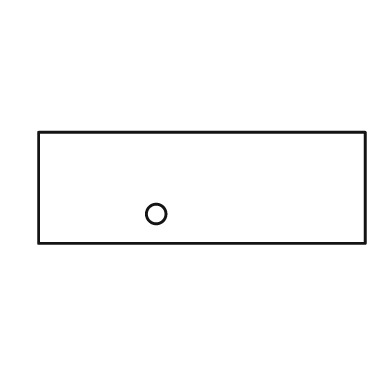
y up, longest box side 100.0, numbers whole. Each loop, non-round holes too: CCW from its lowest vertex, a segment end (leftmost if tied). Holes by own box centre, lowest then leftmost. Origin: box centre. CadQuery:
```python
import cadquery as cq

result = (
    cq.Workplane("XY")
    .moveTo(-50.0, -17.0)
    .lineTo(50.0, -17.0)
    .lineTo(50.0, 17.0)
    .lineTo(-50.0, 17.0)
    .close()
    .moveTo(-14.0, -8.0)
    .circle(3.0)
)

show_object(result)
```